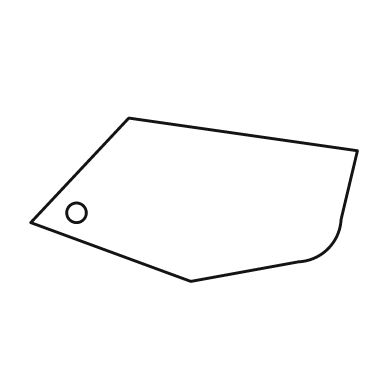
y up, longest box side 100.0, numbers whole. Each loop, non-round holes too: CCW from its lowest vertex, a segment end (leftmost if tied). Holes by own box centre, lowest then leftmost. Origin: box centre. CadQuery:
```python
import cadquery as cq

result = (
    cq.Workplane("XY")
    .moveTo(-1.0, -25.0)
    .lineTo(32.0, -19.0)
    .threePointArc((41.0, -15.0), (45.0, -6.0))
    .lineTo(50.0, 15.0)
    .lineTo(-20.0, 25.0)
    .lineTo(-50.0, -7.0)
    .close()
    .moveTo(-36.0, -4.0)
    .circle(3.0)
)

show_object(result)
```